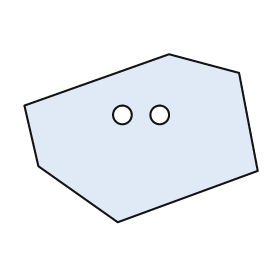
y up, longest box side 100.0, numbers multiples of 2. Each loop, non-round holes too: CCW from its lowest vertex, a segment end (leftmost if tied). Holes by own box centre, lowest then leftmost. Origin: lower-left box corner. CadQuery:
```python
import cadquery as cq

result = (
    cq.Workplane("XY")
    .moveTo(40.0, 0.0)
    .lineTo(100.0, 22.0)
    .lineTo(92.0, 64.0)
    .lineTo(62.0, 72.0)
    .lineTo(0.0, 50.0)
    .lineTo(6.0, 24.0)
    .close()
    .moveTo(42.0, 46.0)
    .circle(4.0)
    .moveTo(58.0, 46.0)
    .circle(4.0)
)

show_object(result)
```